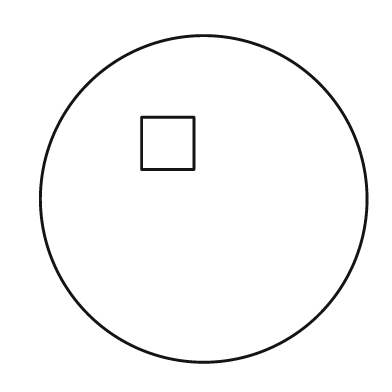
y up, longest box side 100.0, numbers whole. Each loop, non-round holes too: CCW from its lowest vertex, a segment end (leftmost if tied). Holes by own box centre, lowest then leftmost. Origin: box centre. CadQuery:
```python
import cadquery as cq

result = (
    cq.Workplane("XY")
    .moveTo(0.0, 0.0)
    .circle(50.0)
    .moveTo(-19.0, 9.0)
    .lineTo(-3.0, 9.0)
    .lineTo(-3.0, 25.0)
    .lineTo(-19.0, 25.0)
    .close()
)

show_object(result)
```